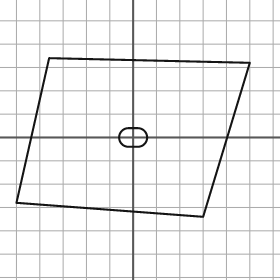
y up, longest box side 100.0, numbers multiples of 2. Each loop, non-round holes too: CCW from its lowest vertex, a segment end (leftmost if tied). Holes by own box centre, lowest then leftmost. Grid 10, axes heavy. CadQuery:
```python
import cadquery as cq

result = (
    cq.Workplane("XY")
    .moveTo(30.0, -34.0)
    .lineTo(50.0, 32.0)
    .lineTo(-36.0, 34.0)
    .lineTo(-50.0, -28.0)
    .close()
    .moveTo(-2.0, -4.0)
    .lineTo(2.0, -4.0)
    .threePointArc((6.0, 0.0), (2.0, 4.0))
    .lineTo(-2.0, 4.0)
    .threePointArc((-6.0, 0.0), (-2.0, -4.0))
    .close()
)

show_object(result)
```